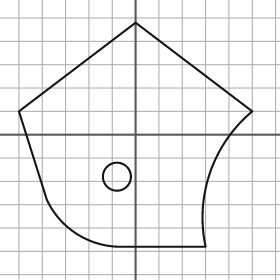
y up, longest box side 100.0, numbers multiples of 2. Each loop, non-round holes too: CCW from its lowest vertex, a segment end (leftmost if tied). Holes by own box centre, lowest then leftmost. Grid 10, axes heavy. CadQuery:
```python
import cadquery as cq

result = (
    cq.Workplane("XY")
    .moveTo(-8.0, -48.0)
    .lineTo(30.0, -48.0)
    .threePointArc((32.0, -16.0), (50.0, 10.0))
    .lineTo(0.0, 48.0)
    .lineTo(-50.0, 10.0)
    .lineTo(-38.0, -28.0)
    .threePointArc((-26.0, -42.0), (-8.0, -48.0))
    .close()
    .moveTo(-8.0, -18.0)
    .circle(6.0)
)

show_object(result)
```